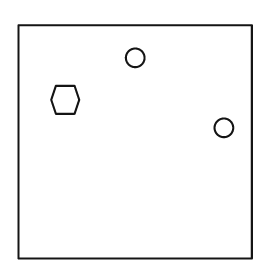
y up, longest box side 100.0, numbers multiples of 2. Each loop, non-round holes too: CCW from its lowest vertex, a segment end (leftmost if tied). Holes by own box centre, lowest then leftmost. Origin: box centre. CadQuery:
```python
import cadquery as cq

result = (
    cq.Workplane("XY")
    .moveTo(-50.0, -50.0)
    .lineTo(50.0, -50.0)
    .lineTo(50.0, 50.0)
    .lineTo(-50.0, 50.0)
    .close()
    .moveTo(38.0, 6.0)
    .circle(4.0)
    .moveTo(-34.0, 12.0)
    .lineTo(-26.0, 12.0)
    .lineTo(-24.0, 18.0)
    .lineTo(-26.0, 24.0)
    .lineTo(-34.0, 24.0)
    .lineTo(-36.0, 18.0)
    .close()
    .moveTo(0.0, 36.0)
    .circle(4.0)
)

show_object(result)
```